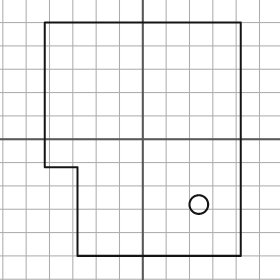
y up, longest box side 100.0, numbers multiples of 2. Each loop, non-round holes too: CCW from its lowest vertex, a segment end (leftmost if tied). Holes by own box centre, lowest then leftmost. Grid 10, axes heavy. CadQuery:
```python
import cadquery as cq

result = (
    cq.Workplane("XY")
    .moveTo(-28.0, -50.0)
    .lineTo(42.0, -50.0)
    .lineTo(42.0, 50.0)
    .lineTo(-42.0, 50.0)
    .lineTo(-42.0, -12.0)
    .lineTo(-28.0, -12.0)
    .close()
    .moveTo(24.0, -28.0)
    .circle(4.0)
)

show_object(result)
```